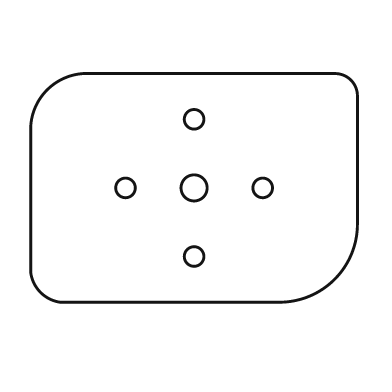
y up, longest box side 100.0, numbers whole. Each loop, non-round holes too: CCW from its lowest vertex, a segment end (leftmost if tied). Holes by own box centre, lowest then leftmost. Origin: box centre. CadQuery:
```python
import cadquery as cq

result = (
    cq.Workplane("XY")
    .moveTo(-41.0, -35.0)
    .lineTo(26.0, -35.0)
    .threePointArc((43.0, -28.0), (50.0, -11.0))
    .lineTo(50.0, 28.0)
    .threePointArc((48.0, 33.0), (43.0, 35.0))
    .lineTo(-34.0, 35.0)
    .threePointArc((-45.0, 30.0), (-50.0, 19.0))
    .lineTo(-50.0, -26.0)
    .threePointArc((-47.0, -32.0), (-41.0, -35.0))
    .close()
    .moveTo(0.0, -21.0)
    .circle(3.0)
    .moveTo(-21.0, 0.0)
    .circle(3.0)
    .moveTo(0.0, 0.0)
    .circle(4.0)
    .moveTo(21.0, 0.0)
    .circle(3.0)
    .moveTo(0.0, 21.0)
    .circle(3.0)
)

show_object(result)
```